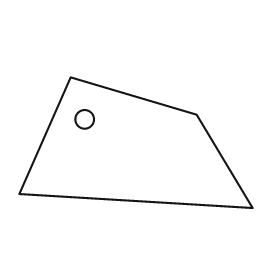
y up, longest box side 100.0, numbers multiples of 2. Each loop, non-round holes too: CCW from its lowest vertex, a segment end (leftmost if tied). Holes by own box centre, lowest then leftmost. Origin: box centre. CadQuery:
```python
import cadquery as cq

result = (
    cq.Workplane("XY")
    .moveTo(50.0, -28.0)
    .lineTo(26.0, 12.0)
    .lineTo(-28.0, 28.0)
    .lineTo(-50.0, -22.0)
    .close()
    .moveTo(-22.0, 10.0)
    .circle(4.0)
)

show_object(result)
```